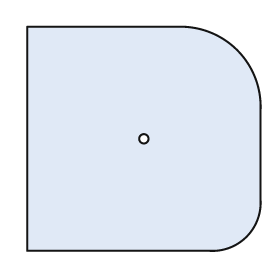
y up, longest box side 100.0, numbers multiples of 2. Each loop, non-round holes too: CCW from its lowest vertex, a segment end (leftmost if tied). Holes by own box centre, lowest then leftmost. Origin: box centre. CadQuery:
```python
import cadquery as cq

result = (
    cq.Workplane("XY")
    .moveTo(-50.0, -48.0)
    .lineTo(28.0, -48.0)
    .threePointArc((44.0, -42.0), (50.0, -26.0))
    .lineTo(50.0, 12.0)
    .threePointArc((40.0, 38.0), (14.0, 48.0))
    .lineTo(-50.0, 48.0)
    .close()
    .moveTo(0.0, 0.0)
    .circle(2.0)
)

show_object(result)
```